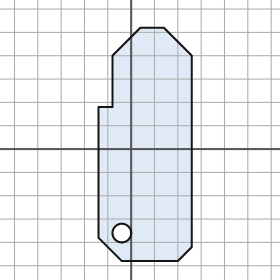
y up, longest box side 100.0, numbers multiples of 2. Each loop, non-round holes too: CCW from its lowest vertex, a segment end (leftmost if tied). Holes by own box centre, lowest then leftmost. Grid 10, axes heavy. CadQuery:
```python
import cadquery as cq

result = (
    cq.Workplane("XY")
    .moveTo(-4.0, -48.0)
    .lineTo(20.0, -48.0)
    .lineTo(26.0, -42.0)
    .lineTo(26.0, 40.0)
    .lineTo(14.0, 52.0)
    .lineTo(4.0, 52.0)
    .lineTo(-8.0, 40.0)
    .lineTo(-8.0, 18.0)
    .lineTo(-14.0, 18.0)
    .lineTo(-14.0, -38.0)
    .close()
    .moveTo(-4.0, -36.0)
    .circle(4.0)
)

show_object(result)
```